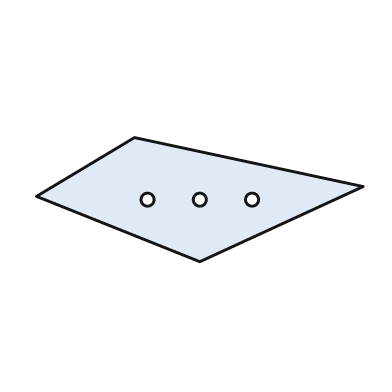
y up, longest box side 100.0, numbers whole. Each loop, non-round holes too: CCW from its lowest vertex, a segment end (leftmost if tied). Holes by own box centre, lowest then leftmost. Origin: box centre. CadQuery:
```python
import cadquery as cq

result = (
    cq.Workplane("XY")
    .moveTo(0.0, -19.0)
    .lineTo(50.0, 4.0)
    .lineTo(-20.0, 19.0)
    .lineTo(-50.0, 1.0)
    .close()
    .moveTo(-16.0, 0.0)
    .circle(2.0)
    .moveTo(0.0, 0.0)
    .circle(2.0)
    .moveTo(16.0, 0.0)
    .circle(2.0)
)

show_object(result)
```